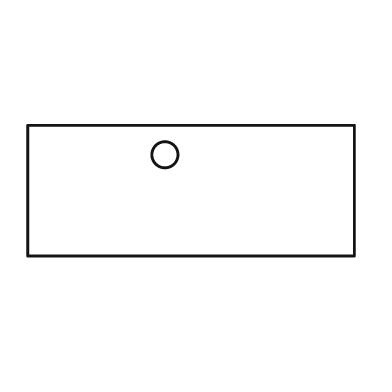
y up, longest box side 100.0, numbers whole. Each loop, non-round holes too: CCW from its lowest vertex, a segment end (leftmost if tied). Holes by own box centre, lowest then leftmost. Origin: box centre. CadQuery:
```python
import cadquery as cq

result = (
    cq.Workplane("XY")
    .moveTo(-50.0, -20.0)
    .lineTo(50.0, -20.0)
    .lineTo(50.0, 20.0)
    .lineTo(-50.0, 20.0)
    .close()
    .moveTo(-8.0, 11.0)
    .circle(4.0)
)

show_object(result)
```